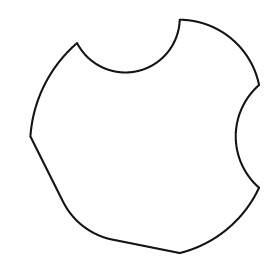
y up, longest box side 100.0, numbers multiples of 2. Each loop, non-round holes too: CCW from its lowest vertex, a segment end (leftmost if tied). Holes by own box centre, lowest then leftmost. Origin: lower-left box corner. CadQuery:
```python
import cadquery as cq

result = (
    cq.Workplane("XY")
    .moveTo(64.0, 0.0)
    .threePointArc((84.0, 10.0), (98.0, 28.0))
    .threePointArc((88.0, 50.0), (98.0, 72.0))
    .threePointArc((86.0, 92.0), (64.0, 100.0))
    .threePointArc((46.0, 78.0), (20.0, 90.0))
    .threePointArc((6.0, 72.0), (0.0, 50.0))
    .lineTo(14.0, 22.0)
    .threePointArc((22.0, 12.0), (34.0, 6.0))
    .close()
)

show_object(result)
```